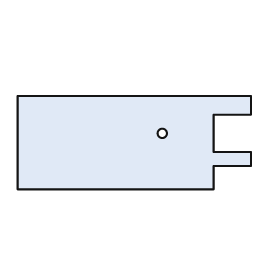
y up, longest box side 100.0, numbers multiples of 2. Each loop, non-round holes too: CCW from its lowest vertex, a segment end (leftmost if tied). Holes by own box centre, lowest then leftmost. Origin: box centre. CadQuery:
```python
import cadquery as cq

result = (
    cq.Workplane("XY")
    .moveTo(-50.0, -20.0)
    .lineTo(34.0, -20.0)
    .lineTo(34.0, -10.0)
    .lineTo(50.0, -10.0)
    .lineTo(50.0, -4.0)
    .lineTo(34.0, -4.0)
    .lineTo(34.0, 12.0)
    .lineTo(50.0, 12.0)
    .lineTo(50.0, 20.0)
    .lineTo(-50.0, 20.0)
    .close()
    .moveTo(12.0, 4.0)
    .circle(2.0)
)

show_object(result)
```